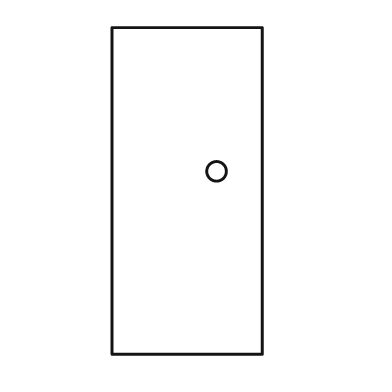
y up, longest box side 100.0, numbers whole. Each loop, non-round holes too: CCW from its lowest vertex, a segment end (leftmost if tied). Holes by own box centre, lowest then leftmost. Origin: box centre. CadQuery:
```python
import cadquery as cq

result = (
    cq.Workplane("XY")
    .moveTo(-23.0, -50.0)
    .lineTo(23.0, -50.0)
    .lineTo(23.0, 50.0)
    .lineTo(-23.0, 50.0)
    .close()
    .moveTo(9.0, 6.0)
    .circle(3.0)
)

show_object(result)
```